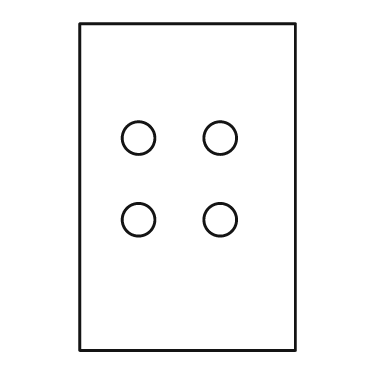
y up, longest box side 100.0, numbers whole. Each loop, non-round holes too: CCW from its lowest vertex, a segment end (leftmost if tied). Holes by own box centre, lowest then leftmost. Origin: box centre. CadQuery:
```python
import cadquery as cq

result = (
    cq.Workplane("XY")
    .moveTo(-33.0, -50.0)
    .lineTo(33.0, -50.0)
    .lineTo(33.0, 50.0)
    .lineTo(-33.0, 50.0)
    .close()
    .moveTo(-15.0, -10.0)
    .circle(5.0)
    .moveTo(10.0, -10.0)
    .circle(5.0)
    .moveTo(-15.0, 15.0)
    .circle(5.0)
    .moveTo(10.0, 15.0)
    .circle(5.0)
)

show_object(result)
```